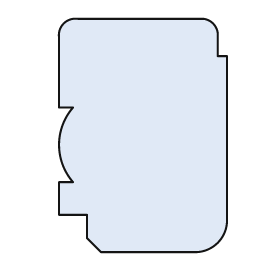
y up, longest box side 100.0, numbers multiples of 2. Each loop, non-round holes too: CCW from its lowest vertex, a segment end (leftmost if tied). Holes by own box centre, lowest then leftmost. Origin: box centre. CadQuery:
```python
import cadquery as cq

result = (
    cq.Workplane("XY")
    .moveTo(-18.0, -50.0)
    .lineTo(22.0, -50.0)
    .threePointArc((32.0, -46.0), (36.0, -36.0))
    .lineTo(36.0, 34.0)
    .lineTo(32.0, 34.0)
    .lineTo(32.0, 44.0)
    .threePointArc((30.0, 48.0), (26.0, 50.0))
    .lineTo(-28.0, 50.0)
    .threePointArc((-34.0, 48.0), (-36.0, 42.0))
    .lineTo(-36.0, 12.0)
    .lineTo(-30.0, 12.0)
    .threePointArc((-36.0, -4.0), (-30.0, -20.0))
    .lineTo(-36.0, -20.0)
    .lineTo(-36.0, -34.0)
    .lineTo(-24.0, -34.0)
    .lineTo(-24.0, -44.0)
    .close()
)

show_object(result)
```